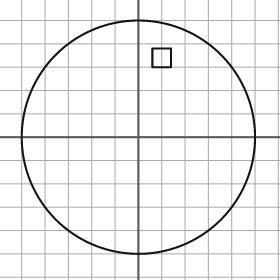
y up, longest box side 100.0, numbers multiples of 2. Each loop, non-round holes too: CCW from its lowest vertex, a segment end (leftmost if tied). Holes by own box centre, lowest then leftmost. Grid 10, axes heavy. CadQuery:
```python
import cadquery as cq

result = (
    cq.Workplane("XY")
    .moveTo(0.0, 0.0)
    .circle(50.0)
    .moveTo(6.0, 30.0)
    .lineTo(14.0, 30.0)
    .lineTo(14.0, 38.0)
    .lineTo(6.0, 38.0)
    .close()
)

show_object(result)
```